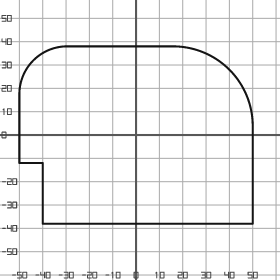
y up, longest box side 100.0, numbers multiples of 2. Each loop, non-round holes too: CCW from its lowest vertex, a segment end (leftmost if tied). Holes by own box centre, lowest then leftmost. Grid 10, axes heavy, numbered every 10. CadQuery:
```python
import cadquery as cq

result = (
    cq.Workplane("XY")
    .moveTo(-40.0, -38.0)
    .lineTo(50.0, -38.0)
    .lineTo(50.0, 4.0)
    .threePointArc((40.0, 28.0), (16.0, 38.0))
    .lineTo(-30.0, 38.0)
    .threePointArc((-44.0, 32.0), (-50.0, 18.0))
    .lineTo(-50.0, -12.0)
    .lineTo(-40.0, -12.0)
    .close()
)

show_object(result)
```